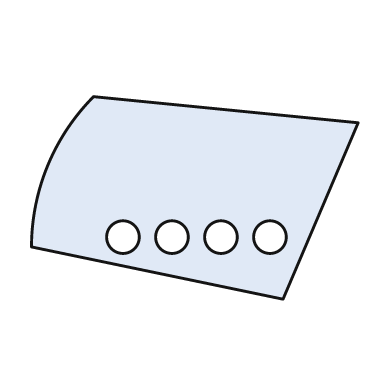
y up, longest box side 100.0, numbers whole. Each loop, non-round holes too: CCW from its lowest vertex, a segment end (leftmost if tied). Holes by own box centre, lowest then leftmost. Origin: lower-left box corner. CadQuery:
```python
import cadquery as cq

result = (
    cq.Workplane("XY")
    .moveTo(77.0, 0.0)
    .lineTo(100.0, 54.0)
    .lineTo(19.0, 62.0)
    .threePointArc((5.0, 41.0), (0.0, 16.0))
    .close()
    .moveTo(28.0, 19.0)
    .circle(5.0)
    .moveTo(43.0, 19.0)
    .circle(5.0)
    .moveTo(58.0, 19.0)
    .circle(5.0)
    .moveTo(73.0, 19.0)
    .circle(5.0)
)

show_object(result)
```